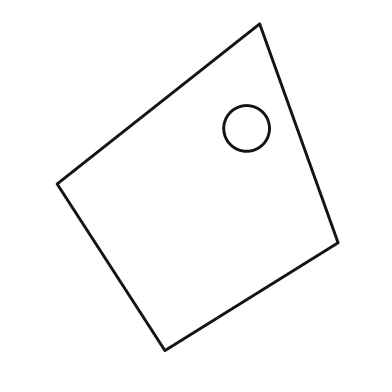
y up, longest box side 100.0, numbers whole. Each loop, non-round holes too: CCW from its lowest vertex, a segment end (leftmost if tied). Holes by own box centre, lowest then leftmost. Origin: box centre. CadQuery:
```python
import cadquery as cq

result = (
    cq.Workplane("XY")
    .moveTo(-10.0, -50.0)
    .lineTo(43.0, -17.0)
    .lineTo(19.0, 50.0)
    .lineTo(-43.0, 1.0)
    .close()
    .moveTo(15.0, 18.0)
    .circle(7.0)
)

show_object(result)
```